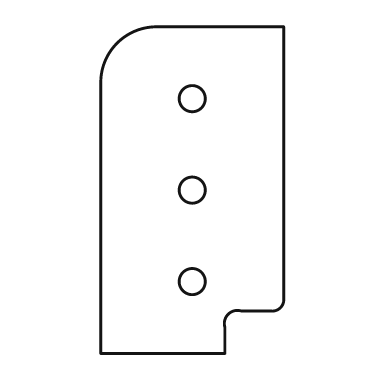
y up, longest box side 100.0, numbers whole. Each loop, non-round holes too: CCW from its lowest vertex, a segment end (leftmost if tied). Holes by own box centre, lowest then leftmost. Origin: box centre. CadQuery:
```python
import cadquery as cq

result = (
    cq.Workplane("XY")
    .moveTo(-28.0, -50.0)
    .lineTo(10.0, -50.0)
    .lineTo(10.0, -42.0)
    .threePointArc((11.0, -38.0), (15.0, -37.0))
    .lineTo(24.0, -37.0)
    .threePointArc((27.0, -36.0), (28.0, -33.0))
    .lineTo(28.0, 50.0)
    .lineTo(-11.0, 50.0)
    .threePointArc((-23.0, 45.0), (-28.0, 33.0))
    .close()
    .moveTo(0.0, -28.0)
    .circle(4.0)
    .moveTo(0.0, 0.0)
    .circle(4.0)
    .moveTo(0.0, 28.0)
    .circle(4.0)
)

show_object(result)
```